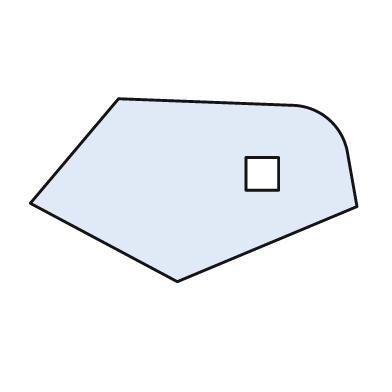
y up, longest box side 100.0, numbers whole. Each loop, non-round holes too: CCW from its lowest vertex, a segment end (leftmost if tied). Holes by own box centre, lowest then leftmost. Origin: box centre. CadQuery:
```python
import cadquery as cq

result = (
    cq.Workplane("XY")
    .moveTo(-5.0, -28.0)
    .lineTo(50.0, -5.0)
    .lineTo(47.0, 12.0)
    .threePointArc((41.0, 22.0), (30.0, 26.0))
    .lineTo(-23.0, 28.0)
    .lineTo(-50.0, -4.0)
    .close()
    .moveTo(16.0, 0.0)
    .lineTo(26.0, 0.0)
    .lineTo(26.0, 10.0)
    .lineTo(16.0, 10.0)
    .close()
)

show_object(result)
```